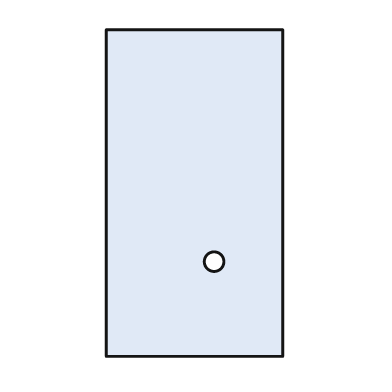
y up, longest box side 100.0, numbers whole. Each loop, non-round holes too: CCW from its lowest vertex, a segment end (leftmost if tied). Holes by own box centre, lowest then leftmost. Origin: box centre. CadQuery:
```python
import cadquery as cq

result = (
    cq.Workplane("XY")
    .moveTo(-27.0, -50.0)
    .lineTo(27.0, -50.0)
    .lineTo(27.0, 50.0)
    .lineTo(-27.0, 50.0)
    .close()
    .moveTo(6.0, -21.0)
    .circle(3.0)
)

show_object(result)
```